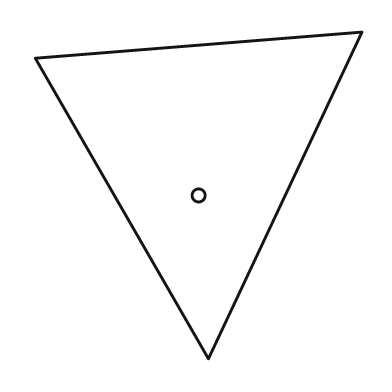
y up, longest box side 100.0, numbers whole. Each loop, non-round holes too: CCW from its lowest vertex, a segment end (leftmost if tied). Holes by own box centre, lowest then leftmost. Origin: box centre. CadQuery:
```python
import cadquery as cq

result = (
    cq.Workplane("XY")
    .moveTo(3.0, -50.0)
    .lineTo(50.0, 50.0)
    .lineTo(-50.0, 42.0)
    .close()
    .moveTo(0.0, 0.0)
    .circle(2.0)
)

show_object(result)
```